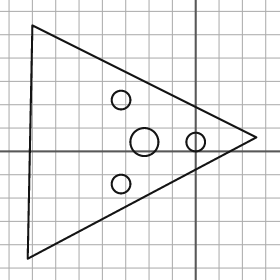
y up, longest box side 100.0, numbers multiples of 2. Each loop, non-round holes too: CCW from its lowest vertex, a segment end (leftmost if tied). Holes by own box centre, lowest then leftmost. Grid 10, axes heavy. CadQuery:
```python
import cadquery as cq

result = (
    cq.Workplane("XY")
    .moveTo(-72.0, -46.0)
    .lineTo(26.0, 6.0)
    .lineTo(-70.0, 54.0)
    .close()
    .moveTo(-32.0, -14.0)
    .circle(4.0)
    .moveTo(-22.0, 4.0)
    .circle(6.0)
    .moveTo(0.0, 4.0)
    .circle(4.0)
    .moveTo(-32.0, 22.0)
    .circle(4.0)
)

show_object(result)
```